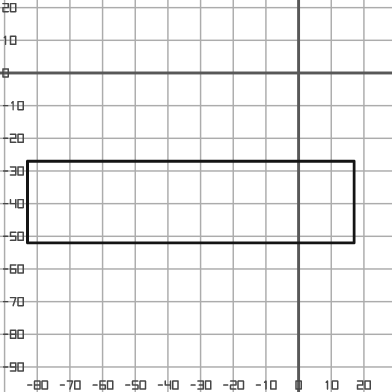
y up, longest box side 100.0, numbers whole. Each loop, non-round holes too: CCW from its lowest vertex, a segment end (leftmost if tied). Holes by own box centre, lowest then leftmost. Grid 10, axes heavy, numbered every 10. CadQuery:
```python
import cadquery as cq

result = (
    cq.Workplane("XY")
    .moveTo(-83.0, -52.0)
    .lineTo(17.0, -52.0)
    .lineTo(17.0, -27.0)
    .lineTo(-83.0, -27.0)
    .close()
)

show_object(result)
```